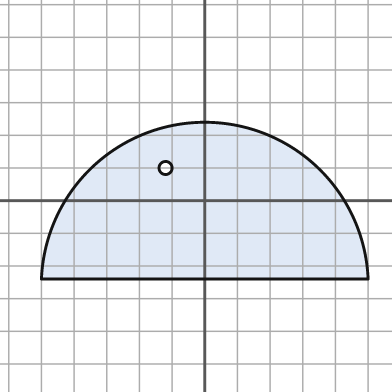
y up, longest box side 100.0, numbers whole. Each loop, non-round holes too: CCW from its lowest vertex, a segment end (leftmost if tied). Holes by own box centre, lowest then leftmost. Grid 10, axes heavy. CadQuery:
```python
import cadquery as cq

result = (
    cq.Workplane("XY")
    .moveTo(-50.0, -24.0)
    .lineTo(50.0, -24.0)
    .threePointArc((0.0, 24.0), (-50.0, -24.0))
    .close()
    .moveTo(-12.0, 10.0)
    .circle(2.0)
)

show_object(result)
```